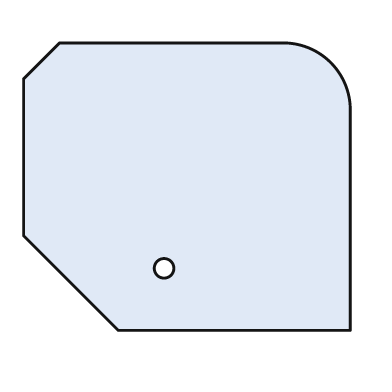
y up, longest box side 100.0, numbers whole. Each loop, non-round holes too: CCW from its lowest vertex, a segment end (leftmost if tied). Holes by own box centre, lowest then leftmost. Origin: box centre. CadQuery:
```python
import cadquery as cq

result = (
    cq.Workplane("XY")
    .moveTo(-21.0, -44.0)
    .lineTo(50.0, -44.0)
    .lineTo(50.0, 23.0)
    .threePointArc((44.0, 38.0), (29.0, 44.0))
    .lineTo(-39.0, 44.0)
    .lineTo(-50.0, 33.0)
    .lineTo(-50.0, -15.0)
    .close()
    .moveTo(-7.0, -25.0)
    .circle(3.0)
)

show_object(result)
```